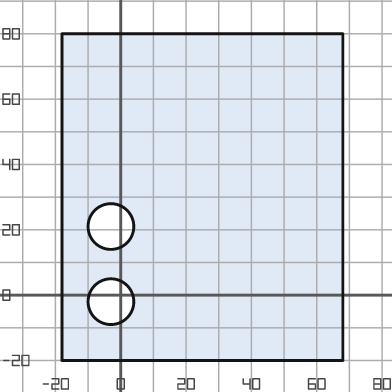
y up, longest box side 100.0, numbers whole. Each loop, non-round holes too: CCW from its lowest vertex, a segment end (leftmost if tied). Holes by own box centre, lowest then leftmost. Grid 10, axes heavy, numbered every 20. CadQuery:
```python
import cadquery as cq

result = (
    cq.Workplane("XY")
    .moveTo(-18.0, -20.0)
    .lineTo(68.0, -20.0)
    .lineTo(68.0, 80.0)
    .lineTo(-18.0, 80.0)
    .close()
    .moveTo(-3.0, -2.0)
    .circle(7.0)
    .moveTo(-3.0, 21.0)
    .circle(7.0)
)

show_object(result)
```